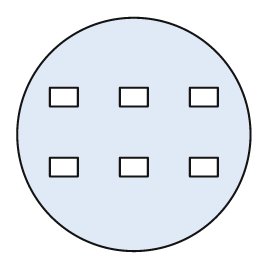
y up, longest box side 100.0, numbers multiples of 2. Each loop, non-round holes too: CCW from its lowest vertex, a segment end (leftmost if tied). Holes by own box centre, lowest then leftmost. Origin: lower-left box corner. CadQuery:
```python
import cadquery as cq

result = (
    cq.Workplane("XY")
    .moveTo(50.0, 50.0)
    .circle(50.0)
    .moveTo(14.0, 32.0)
    .lineTo(26.0, 32.0)
    .lineTo(26.0, 40.0)
    .lineTo(14.0, 40.0)
    .close()
    .moveTo(44.0, 32.0)
    .lineTo(56.0, 32.0)
    .lineTo(56.0, 40.0)
    .lineTo(44.0, 40.0)
    .close()
    .moveTo(74.0, 32.0)
    .lineTo(86.0, 32.0)
    .lineTo(86.0, 40.0)
    .lineTo(74.0, 40.0)
    .close()
    .moveTo(14.0, 62.0)
    .lineTo(26.0, 62.0)
    .lineTo(26.0, 70.0)
    .lineTo(14.0, 70.0)
    .close()
    .moveTo(44.0, 62.0)
    .lineTo(56.0, 62.0)
    .lineTo(56.0, 70.0)
    .lineTo(44.0, 70.0)
    .close()
    .moveTo(74.0, 62.0)
    .lineTo(86.0, 62.0)
    .lineTo(86.0, 70.0)
    .lineTo(74.0, 70.0)
    .close()
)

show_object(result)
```